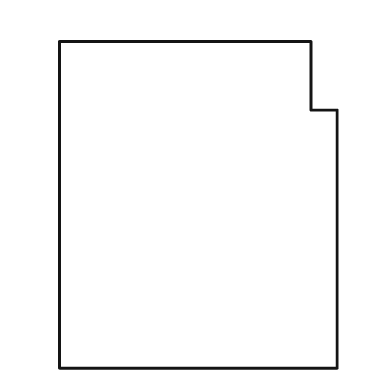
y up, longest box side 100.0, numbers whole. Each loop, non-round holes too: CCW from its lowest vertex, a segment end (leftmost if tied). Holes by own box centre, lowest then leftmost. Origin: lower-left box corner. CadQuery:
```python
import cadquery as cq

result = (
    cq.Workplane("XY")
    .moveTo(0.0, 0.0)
    .lineTo(85.0, 0.0)
    .lineTo(85.0, 79.0)
    .lineTo(77.0, 79.0)
    .lineTo(77.0, 100.0)
    .lineTo(0.0, 100.0)
    .close()
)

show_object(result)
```